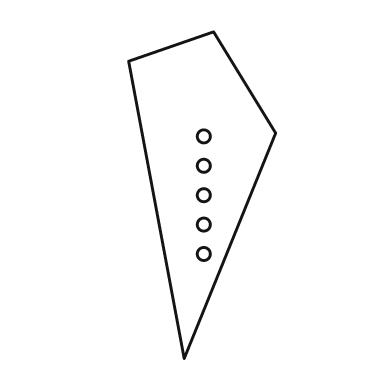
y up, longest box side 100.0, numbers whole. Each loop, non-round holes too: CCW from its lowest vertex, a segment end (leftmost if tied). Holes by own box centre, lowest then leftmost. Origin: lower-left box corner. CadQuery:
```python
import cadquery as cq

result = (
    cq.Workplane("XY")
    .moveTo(17.0, 0.0)
    .lineTo(45.0, 69.0)
    .lineTo(26.0, 100.0)
    .lineTo(0.0, 91.0)
    .close()
    .moveTo(23.0, 32.0)
    .circle(2.0)
    .moveTo(23.0, 41.0)
    .circle(2.0)
    .moveTo(23.0, 50.0)
    .circle(2.0)
    .moveTo(23.0, 59.0)
    .circle(2.0)
    .moveTo(23.0, 68.0)
    .circle(2.0)
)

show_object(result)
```